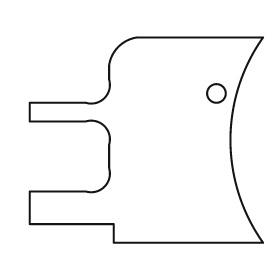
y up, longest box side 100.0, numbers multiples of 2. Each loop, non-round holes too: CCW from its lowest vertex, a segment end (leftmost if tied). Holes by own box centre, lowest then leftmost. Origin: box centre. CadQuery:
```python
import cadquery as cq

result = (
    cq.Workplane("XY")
    .moveTo(-14.0, -44.0)
    .lineTo(50.0, -44.0)
    .threePointArc((36.0, 0.0), (50.0, 44.0))
    .lineTo(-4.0, 44.0)
    .threePointArc((-12.0, 40.0), (-16.0, 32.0))
    .lineTo(-16.0, 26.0)
    .threePointArc((-18.0, 18.0), (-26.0, 16.0))
    .lineTo(-50.0, 16.0)
    .lineTo(-50.0, 8.0)
    .lineTo(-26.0, 8.0)
    .threePointArc((-18.0, 6.0), (-16.0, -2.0))
    .lineTo(-16.0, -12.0)
    .threePointArc((-18.0, -20.0), (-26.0, -22.0))
    .lineTo(-50.0, -22.0)
    .lineTo(-50.0, -36.0)
    .lineTo(-14.0, -36.0)
    .close()
    .moveTo(30.0, 20.0)
    .circle(4.0)
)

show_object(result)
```